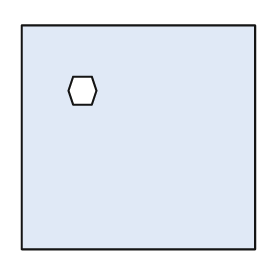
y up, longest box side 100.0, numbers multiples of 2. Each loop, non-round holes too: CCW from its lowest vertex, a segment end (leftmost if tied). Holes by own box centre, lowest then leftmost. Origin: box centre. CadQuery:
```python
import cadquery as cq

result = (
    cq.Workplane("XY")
    .moveTo(-50.0, -48.0)
    .lineTo(50.0, -48.0)
    .lineTo(50.0, 48.0)
    .lineTo(-50.0, 48.0)
    .close()
    .moveTo(-28.0, 14.0)
    .lineTo(-20.0, 14.0)
    .lineTo(-18.0, 20.0)
    .lineTo(-20.0, 26.0)
    .lineTo(-28.0, 26.0)
    .lineTo(-30.0, 20.0)
    .close()
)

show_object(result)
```